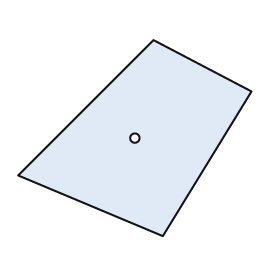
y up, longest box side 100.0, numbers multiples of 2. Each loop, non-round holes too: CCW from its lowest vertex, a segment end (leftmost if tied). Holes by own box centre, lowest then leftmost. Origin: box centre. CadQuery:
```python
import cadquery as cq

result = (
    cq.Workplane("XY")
    .moveTo(12.0, -42.0)
    .lineTo(50.0, 20.0)
    .lineTo(8.0, 42.0)
    .lineTo(-50.0, -16.0)
    .close()
    .moveTo(0.0, 0.0)
    .circle(2.0)
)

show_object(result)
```